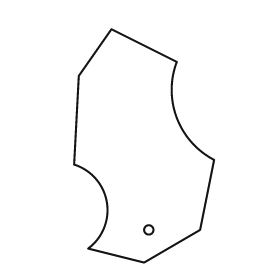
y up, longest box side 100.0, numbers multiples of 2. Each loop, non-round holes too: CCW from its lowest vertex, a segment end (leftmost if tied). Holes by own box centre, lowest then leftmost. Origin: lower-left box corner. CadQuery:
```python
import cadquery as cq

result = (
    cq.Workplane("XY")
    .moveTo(30.0, 0.0)
    .lineTo(54.0, 14.0)
    .lineTo(60.0, 44.0)
    .threePointArc((44.0, 62.0), (44.0, 86.0))
    .lineTo(16.0, 100.0)
    .lineTo(2.0, 80.0)
    .lineTo(0.0, 42.0)
    .threePointArc((14.0, 26.0), (6.0, 6.0))
    .close()
    .moveTo(32.0, 14.0)
    .circle(2.0)
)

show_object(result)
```